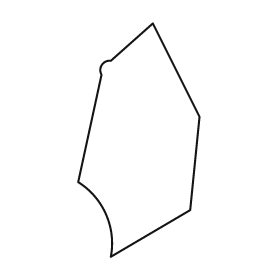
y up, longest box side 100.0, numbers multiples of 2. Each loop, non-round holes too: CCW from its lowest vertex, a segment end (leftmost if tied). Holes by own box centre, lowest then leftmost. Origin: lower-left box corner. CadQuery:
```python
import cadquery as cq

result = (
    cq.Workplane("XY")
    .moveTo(14.0, 0.0)
    .lineTo(48.0, 20.0)
    .lineTo(52.0, 60.0)
    .lineTo(32.0, 100.0)
    .lineTo(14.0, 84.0)
    .threePointArc((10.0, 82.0), (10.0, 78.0))
    .lineTo(0.0, 32.0)
    .threePointArc((12.0, 18.0), (14.0, 0.0))
    .close()
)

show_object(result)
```